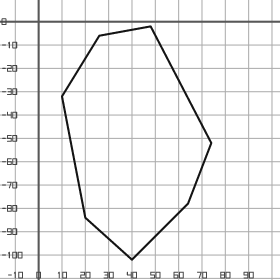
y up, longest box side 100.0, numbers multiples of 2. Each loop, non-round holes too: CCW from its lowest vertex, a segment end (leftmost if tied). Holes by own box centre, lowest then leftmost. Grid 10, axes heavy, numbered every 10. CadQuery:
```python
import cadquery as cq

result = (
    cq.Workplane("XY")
    .moveTo(40.0, -102.0)
    .lineTo(64.0, -78.0)
    .lineTo(74.0, -52.0)
    .lineTo(48.0, -2.0)
    .lineTo(26.0, -6.0)
    .lineTo(10.0, -32.0)
    .lineTo(20.0, -84.0)
    .close()
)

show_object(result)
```